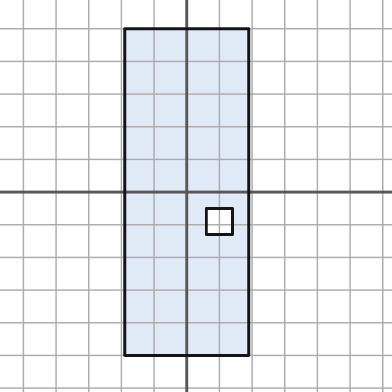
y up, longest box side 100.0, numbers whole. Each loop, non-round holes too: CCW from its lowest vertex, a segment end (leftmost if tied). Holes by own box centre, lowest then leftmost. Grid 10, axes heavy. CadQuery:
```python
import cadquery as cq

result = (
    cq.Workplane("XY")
    .moveTo(-19.0, -50.0)
    .lineTo(19.0, -50.0)
    .lineTo(19.0, 50.0)
    .lineTo(-19.0, 50.0)
    .close()
    .moveTo(6.0, -13.0)
    .lineTo(14.0, -13.0)
    .lineTo(14.0, -5.0)
    .lineTo(6.0, -5.0)
    .close()
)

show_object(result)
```